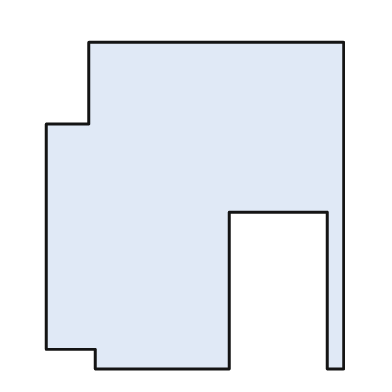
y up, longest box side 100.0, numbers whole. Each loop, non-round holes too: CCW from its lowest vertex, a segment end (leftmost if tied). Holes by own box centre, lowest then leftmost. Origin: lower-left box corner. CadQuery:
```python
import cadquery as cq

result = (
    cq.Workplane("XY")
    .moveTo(15.0, 0.0)
    .lineTo(56.0, 0.0)
    .lineTo(56.0, 48.0)
    .lineTo(86.0, 48.0)
    .lineTo(86.0, 0.0)
    .lineTo(91.0, 0.0)
    .lineTo(91.0, 100.0)
    .lineTo(13.0, 100.0)
    .lineTo(13.0, 75.0)
    .lineTo(0.0, 75.0)
    .lineTo(0.0, 6.0)
    .lineTo(15.0, 6.0)
    .close()
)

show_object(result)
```